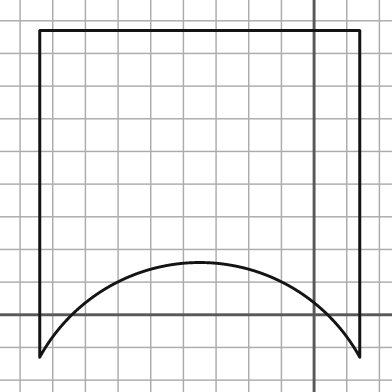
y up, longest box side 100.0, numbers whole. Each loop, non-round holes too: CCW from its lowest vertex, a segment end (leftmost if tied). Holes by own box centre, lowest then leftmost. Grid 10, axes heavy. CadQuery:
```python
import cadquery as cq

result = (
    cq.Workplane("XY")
    .moveTo(-84.0, -13.0)
    .threePointArc((-35.0, 16.0), (14.0, -13.0))
    .lineTo(14.0, 87.0)
    .lineTo(-84.0, 87.0)
    .close()
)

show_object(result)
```